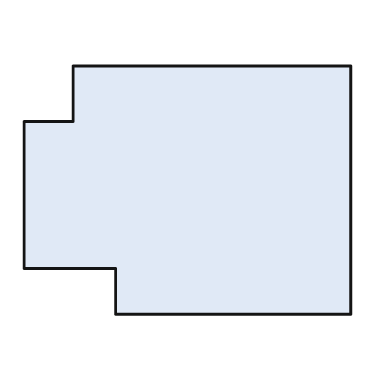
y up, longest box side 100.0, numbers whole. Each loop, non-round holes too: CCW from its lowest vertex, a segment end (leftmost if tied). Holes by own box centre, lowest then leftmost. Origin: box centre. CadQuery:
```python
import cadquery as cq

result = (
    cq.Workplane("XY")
    .moveTo(-22.0, -38.0)
    .lineTo(50.0, -38.0)
    .lineTo(50.0, 38.0)
    .lineTo(-35.0, 38.0)
    .lineTo(-35.0, 21.0)
    .lineTo(-50.0, 21.0)
    .lineTo(-50.0, -24.0)
    .lineTo(-22.0, -24.0)
    .close()
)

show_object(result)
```